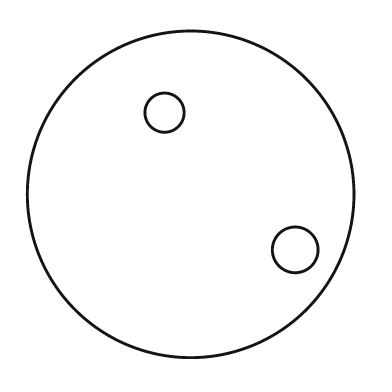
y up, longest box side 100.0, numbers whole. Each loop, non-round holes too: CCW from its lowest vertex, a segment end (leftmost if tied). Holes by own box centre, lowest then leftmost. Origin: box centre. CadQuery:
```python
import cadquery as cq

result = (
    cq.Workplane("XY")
    .moveTo(0.0, 0.0)
    .circle(50.0)
    .moveTo(32.0, -17.0)
    .circle(7.0)
    .moveTo(-8.0, 25.0)
    .circle(6.0)
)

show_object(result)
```